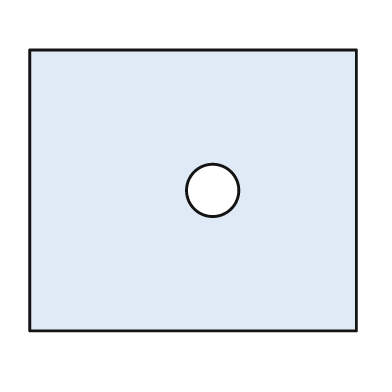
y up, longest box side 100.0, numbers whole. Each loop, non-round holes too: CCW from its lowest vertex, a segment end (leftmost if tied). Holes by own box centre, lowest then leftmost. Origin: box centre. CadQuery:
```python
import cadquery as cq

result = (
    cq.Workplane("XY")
    .moveTo(-50.0, -43.0)
    .lineTo(50.0, -43.0)
    .lineTo(50.0, 43.0)
    .lineTo(-50.0, 43.0)
    .close()
    .moveTo(6.0, 0.0)
    .circle(8.0)
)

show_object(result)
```